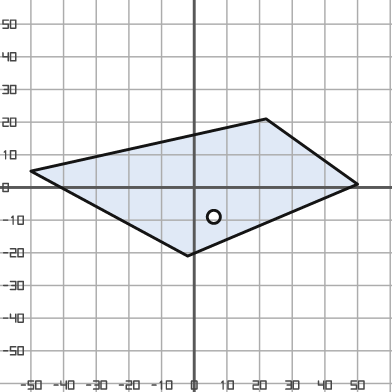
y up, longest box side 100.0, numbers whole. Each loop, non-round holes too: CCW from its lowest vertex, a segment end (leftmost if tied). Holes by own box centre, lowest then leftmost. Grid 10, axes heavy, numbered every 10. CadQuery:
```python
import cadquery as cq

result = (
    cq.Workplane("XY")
    .moveTo(-2.0, -21.0)
    .lineTo(50.0, 1.0)
    .lineTo(22.0, 21.0)
    .lineTo(-50.0, 5.0)
    .close()
    .moveTo(6.0, -9.0)
    .circle(2.0)
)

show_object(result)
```